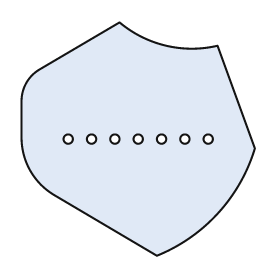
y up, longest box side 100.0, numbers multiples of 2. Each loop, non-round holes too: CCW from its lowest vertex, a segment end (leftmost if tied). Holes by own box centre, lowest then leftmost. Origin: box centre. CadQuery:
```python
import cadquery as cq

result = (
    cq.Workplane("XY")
    .moveTo(8.0, -50.0)
    .threePointArc((34.0, -32.0), (50.0, -4.0))
    .lineTo(34.0, 40.0)
    .threePointArc((12.0, 40.0), (-8.0, 50.0))
    .lineTo(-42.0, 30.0)
    .threePointArc((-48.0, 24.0), (-50.0, 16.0))
    .lineTo(-50.0, 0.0)
    .threePointArc((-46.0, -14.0), (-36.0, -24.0))
    .close()
    .moveTo(-30.0, 0.0)
    .circle(2.0)
    .moveTo(-20.0, 0.0)
    .circle(2.0)
    .moveTo(-10.0, 0.0)
    .circle(2.0)
    .moveTo(0.0, 0.0)
    .circle(2.0)
    .moveTo(10.0, 0.0)
    .circle(2.0)
    .moveTo(20.0, 0.0)
    .circle(2.0)
    .moveTo(30.0, 0.0)
    .circle(2.0)
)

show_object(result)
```